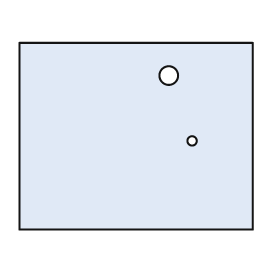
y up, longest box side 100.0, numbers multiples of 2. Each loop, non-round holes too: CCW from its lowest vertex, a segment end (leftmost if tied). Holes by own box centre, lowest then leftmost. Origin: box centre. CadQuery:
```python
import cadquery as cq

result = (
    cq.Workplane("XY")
    .moveTo(-50.0, -40.0)
    .lineTo(50.0, -40.0)
    .lineTo(50.0, 40.0)
    .lineTo(-50.0, 40.0)
    .close()
    .moveTo(24.0, -2.0)
    .circle(2.0)
    .moveTo(14.0, 26.0)
    .circle(4.0)
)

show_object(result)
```